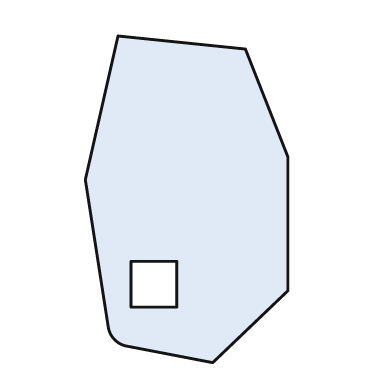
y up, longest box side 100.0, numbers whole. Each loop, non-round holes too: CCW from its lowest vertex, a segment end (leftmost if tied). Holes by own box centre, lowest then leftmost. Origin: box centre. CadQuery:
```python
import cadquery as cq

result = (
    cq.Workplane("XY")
    .moveTo(8.0, -50.0)
    .lineTo(31.0, -28.0)
    .lineTo(31.0, 13.0)
    .lineTo(18.0, 46.0)
    .lineTo(-21.0, 50.0)
    .lineTo(-31.0, 6.0)
    .lineTo(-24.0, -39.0)
    .threePointArc((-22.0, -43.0), (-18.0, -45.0))
    .close()
    .moveTo(-17.0, -33.0)
    .lineTo(-3.0, -33.0)
    .lineTo(-3.0, -19.0)
    .lineTo(-17.0, -19.0)
    .close()
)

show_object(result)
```